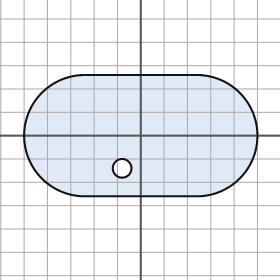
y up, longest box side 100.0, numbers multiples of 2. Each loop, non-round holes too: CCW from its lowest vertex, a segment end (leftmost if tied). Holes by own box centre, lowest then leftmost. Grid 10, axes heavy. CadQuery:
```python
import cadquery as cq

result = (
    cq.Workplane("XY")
    .moveTo(-24.0, -26.0)
    .lineTo(24.0, -26.0)
    .threePointArc((50.0, 0.0), (24.0, 26.0))
    .lineTo(-24.0, 26.0)
    .threePointArc((-50.0, 0.0), (-24.0, -26.0))
    .close()
    .moveTo(-8.0, -14.0)
    .circle(4.0)
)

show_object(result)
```